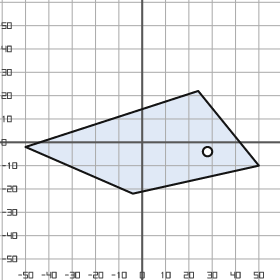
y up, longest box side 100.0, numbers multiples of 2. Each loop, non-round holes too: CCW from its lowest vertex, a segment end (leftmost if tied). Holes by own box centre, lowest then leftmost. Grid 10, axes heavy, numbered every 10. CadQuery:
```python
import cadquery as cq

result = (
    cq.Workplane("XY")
    .moveTo(-4.0, -22.0)
    .lineTo(50.0, -10.0)
    .lineTo(24.0, 22.0)
    .lineTo(-50.0, -2.0)
    .close()
    .moveTo(28.0, -4.0)
    .circle(2.0)
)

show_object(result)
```